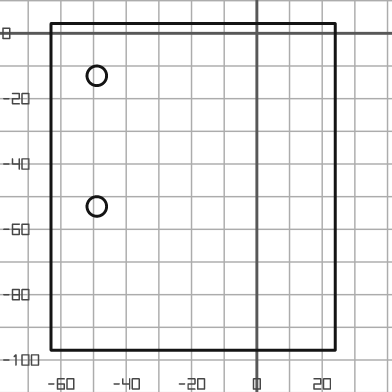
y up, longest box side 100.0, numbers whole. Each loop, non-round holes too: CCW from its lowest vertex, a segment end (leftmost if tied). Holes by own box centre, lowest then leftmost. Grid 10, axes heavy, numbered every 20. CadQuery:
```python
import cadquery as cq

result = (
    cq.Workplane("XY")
    .moveTo(-63.0, -97.0)
    .lineTo(24.0, -97.0)
    .lineTo(24.0, 3.0)
    .lineTo(-63.0, 3.0)
    .close()
    .moveTo(-49.0, -53.0)
    .circle(3.0)
    .moveTo(-49.0, -13.0)
    .circle(3.0)
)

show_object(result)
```